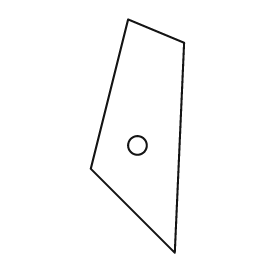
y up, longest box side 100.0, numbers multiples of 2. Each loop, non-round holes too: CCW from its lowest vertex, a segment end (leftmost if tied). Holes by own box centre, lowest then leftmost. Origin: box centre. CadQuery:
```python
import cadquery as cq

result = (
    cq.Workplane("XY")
    .moveTo(16.0, -50.0)
    .lineTo(20.0, 40.0)
    .lineTo(-4.0, 50.0)
    .lineTo(-20.0, -14.0)
    .close()
    .moveTo(0.0, -4.0)
    .circle(4.0)
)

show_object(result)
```